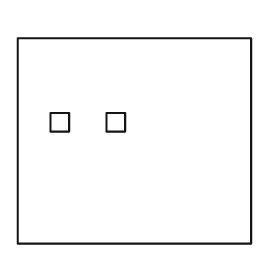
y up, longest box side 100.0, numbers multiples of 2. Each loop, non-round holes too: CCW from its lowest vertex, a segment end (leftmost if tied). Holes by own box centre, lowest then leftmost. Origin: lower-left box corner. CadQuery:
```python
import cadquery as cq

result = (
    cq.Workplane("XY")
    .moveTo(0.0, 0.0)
    .lineTo(100.0, 0.0)
    .lineTo(100.0, 88.0)
    .lineTo(0.0, 88.0)
    .close()
    .moveTo(14.0, 48.0)
    .lineTo(22.0, 48.0)
    .lineTo(22.0, 56.0)
    .lineTo(14.0, 56.0)
    .close()
    .moveTo(38.0, 48.0)
    .lineTo(46.0, 48.0)
    .lineTo(46.0, 56.0)
    .lineTo(38.0, 56.0)
    .close()
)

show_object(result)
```